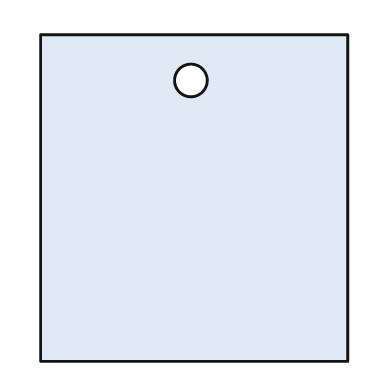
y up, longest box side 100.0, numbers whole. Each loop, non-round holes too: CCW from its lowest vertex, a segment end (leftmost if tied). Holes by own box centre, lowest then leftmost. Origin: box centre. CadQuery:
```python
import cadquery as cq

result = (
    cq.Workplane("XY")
    .moveTo(-47.0, -50.0)
    .lineTo(47.0, -50.0)
    .lineTo(47.0, 50.0)
    .lineTo(-47.0, 50.0)
    .close()
    .moveTo(-1.0, 36.0)
    .circle(5.0)
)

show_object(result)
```